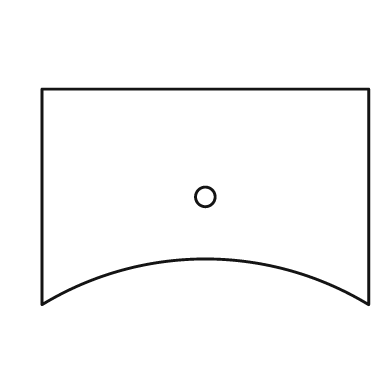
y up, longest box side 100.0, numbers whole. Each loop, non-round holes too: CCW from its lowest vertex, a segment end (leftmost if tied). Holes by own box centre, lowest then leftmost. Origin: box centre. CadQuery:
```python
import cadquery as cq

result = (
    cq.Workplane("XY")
    .moveTo(-50.0, -33.0)
    .threePointArc((0.0, -19.0), (50.0, -33.0))
    .lineTo(50.0, 33.0)
    .lineTo(-50.0, 33.0)
    .close()
    .moveTo(0.0, 0.0)
    .circle(3.0)
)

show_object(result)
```